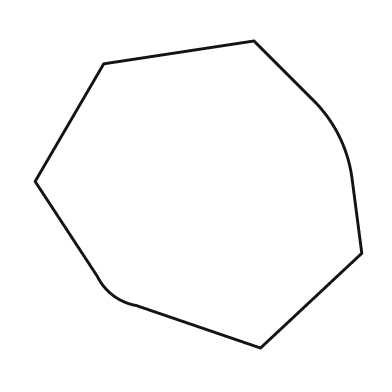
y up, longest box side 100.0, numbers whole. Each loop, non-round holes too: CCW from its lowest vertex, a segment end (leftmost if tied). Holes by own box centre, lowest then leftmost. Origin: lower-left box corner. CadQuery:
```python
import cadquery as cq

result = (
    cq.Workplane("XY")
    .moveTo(69.0, 0.0)
    .lineTo(100.0, 29.0)
    .lineTo(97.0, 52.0)
    .threePointArc((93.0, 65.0), (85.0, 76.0))
    .lineTo(67.0, 94.0)
    .lineTo(21.0, 87.0)
    .lineTo(0.0, 51.0)
    .lineTo(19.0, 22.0)
    .threePointArc((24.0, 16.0), (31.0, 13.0))
    .close()
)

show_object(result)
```